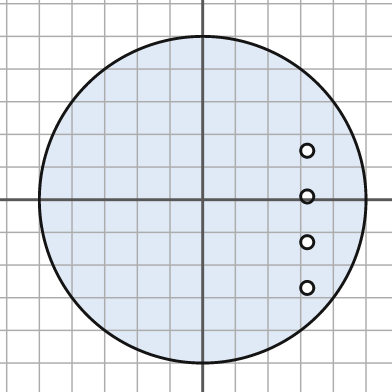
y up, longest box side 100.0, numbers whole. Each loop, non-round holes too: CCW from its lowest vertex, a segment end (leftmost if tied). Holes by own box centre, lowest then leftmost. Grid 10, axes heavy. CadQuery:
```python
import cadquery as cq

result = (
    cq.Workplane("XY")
    .moveTo(0.0, 0.0)
    .circle(50.0)
    .moveTo(32.0, -27.0)
    .circle(2.0)
    .moveTo(32.0, -13.0)
    .circle(2.0)
    .moveTo(32.0, 1.0)
    .circle(2.0)
    .moveTo(32.0, 15.0)
    .circle(2.0)
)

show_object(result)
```